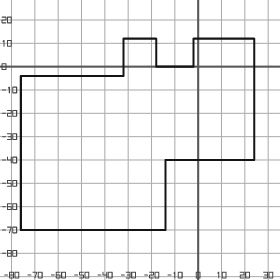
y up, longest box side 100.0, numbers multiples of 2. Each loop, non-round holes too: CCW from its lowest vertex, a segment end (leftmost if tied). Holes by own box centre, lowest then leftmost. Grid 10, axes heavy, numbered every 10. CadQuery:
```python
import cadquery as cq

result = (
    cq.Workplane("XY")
    .moveTo(-76.0, -70.0)
    .lineTo(-14.0, -70.0)
    .lineTo(-14.0, -40.0)
    .lineTo(24.0, -40.0)
    .lineTo(24.0, 12.0)
    .lineTo(-2.0, 12.0)
    .lineTo(-2.0, 0.0)
    .lineTo(-18.0, 0.0)
    .lineTo(-18.0, 12.0)
    .lineTo(-32.0, 12.0)
    .lineTo(-32.0, -4.0)
    .lineTo(-76.0, -4.0)
    .close()
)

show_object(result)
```